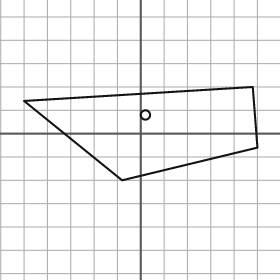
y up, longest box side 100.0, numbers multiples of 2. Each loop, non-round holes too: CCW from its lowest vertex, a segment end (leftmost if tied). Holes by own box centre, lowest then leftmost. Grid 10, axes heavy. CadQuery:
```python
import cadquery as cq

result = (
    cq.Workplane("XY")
    .moveTo(-8.0, -20.0)
    .lineTo(50.0, -6.0)
    .lineTo(48.0, 20.0)
    .lineTo(-50.0, 14.0)
    .close()
    .moveTo(2.0, 8.0)
    .circle(2.0)
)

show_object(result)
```